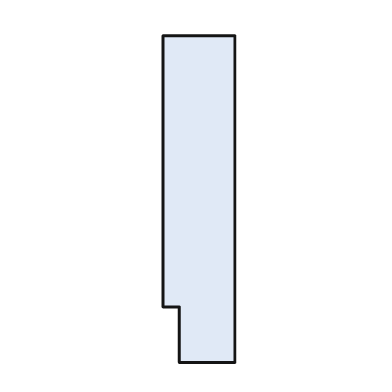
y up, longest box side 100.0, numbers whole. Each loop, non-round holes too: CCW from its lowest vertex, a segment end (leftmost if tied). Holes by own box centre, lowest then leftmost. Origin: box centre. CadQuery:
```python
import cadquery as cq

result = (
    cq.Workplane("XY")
    .moveTo(-6.0, -50.0)
    .lineTo(11.0, -50.0)
    .lineTo(11.0, 50.0)
    .lineTo(-11.0, 50.0)
    .lineTo(-11.0, -33.0)
    .lineTo(-6.0, -33.0)
    .close()
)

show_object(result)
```